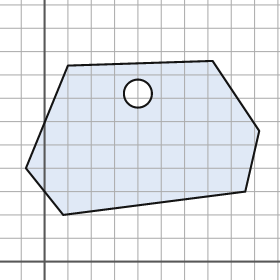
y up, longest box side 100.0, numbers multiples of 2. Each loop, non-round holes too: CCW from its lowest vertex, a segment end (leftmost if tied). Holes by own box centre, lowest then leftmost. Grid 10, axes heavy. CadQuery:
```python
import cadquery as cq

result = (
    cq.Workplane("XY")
    .moveTo(8.0, 20.0)
    .lineTo(86.0, 30.0)
    .lineTo(92.0, 56.0)
    .lineTo(72.0, 86.0)
    .lineTo(10.0, 84.0)
    .lineTo(-8.0, 40.0)
    .close()
    .moveTo(40.0, 72.0)
    .circle(6.0)
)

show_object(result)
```